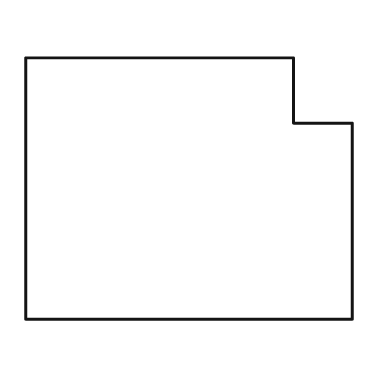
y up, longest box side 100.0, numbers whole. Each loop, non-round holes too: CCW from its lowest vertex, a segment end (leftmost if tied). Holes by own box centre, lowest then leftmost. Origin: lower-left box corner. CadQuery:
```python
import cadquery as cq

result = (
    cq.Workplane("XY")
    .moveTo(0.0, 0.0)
    .lineTo(100.0, 0.0)
    .lineTo(100.0, 60.0)
    .lineTo(82.0, 60.0)
    .lineTo(82.0, 80.0)
    .lineTo(0.0, 80.0)
    .close()
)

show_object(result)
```